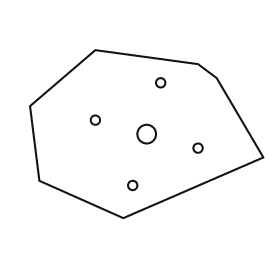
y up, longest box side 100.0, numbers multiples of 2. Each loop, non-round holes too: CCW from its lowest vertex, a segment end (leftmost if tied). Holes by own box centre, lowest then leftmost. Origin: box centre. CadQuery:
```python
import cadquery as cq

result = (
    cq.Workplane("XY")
    .moveTo(-10.0, -36.0)
    .lineTo(50.0, -10.0)
    .lineTo(30.0, 24.0)
    .lineTo(22.0, 30.0)
    .lineTo(-22.0, 36.0)
    .lineTo(-50.0, 12.0)
    .lineTo(-46.0, -20.0)
    .close()
    .moveTo(-6.0, -22.0)
    .circle(2.0)
    .moveTo(22.0, -6.0)
    .circle(2.0)
    .moveTo(0.0, 0.0)
    .circle(4.0)
    .moveTo(-22.0, 6.0)
    .circle(2.0)
    .moveTo(6.0, 22.0)
    .circle(2.0)
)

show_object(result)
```